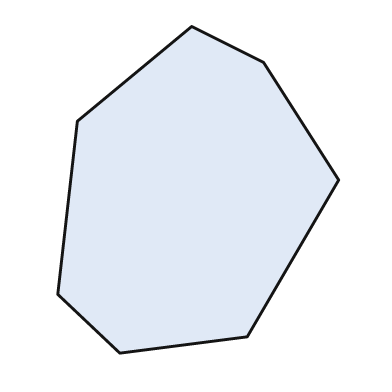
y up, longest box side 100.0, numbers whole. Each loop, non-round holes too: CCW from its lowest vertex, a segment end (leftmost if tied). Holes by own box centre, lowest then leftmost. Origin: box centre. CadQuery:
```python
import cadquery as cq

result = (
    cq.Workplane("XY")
    .moveTo(-24.0, -50.0)
    .lineTo(15.0, -45.0)
    .lineTo(43.0, 3.0)
    .lineTo(20.0, 39.0)
    .lineTo(-2.0, 50.0)
    .lineTo(-37.0, 21.0)
    .lineTo(-43.0, -32.0)
    .close()
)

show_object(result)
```